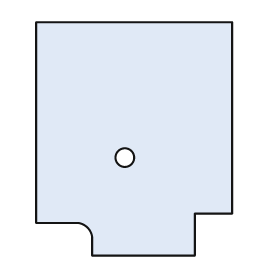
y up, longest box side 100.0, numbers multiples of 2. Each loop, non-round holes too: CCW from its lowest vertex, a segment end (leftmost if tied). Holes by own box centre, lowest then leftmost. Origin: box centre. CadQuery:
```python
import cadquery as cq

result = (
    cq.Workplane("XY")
    .moveTo(-18.0, -50.0)
    .lineTo(26.0, -50.0)
    .lineTo(26.0, -32.0)
    .lineTo(42.0, -32.0)
    .lineTo(42.0, 50.0)
    .lineTo(-42.0, 50.0)
    .lineTo(-42.0, -36.0)
    .lineTo(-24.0, -36.0)
    .threePointArc((-20.0, -38.0), (-18.0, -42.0))
    .close()
    .moveTo(-4.0, -8.0)
    .circle(4.0)
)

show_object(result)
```